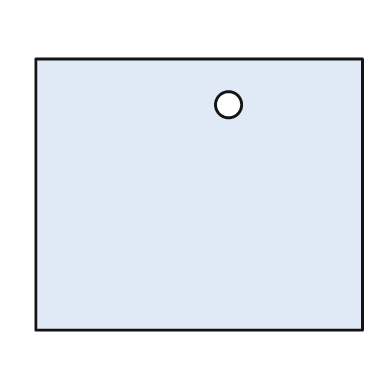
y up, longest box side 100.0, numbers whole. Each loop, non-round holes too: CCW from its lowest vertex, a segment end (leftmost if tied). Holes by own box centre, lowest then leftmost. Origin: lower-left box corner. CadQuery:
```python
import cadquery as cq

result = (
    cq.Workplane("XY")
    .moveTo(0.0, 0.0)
    .lineTo(100.0, 0.0)
    .lineTo(100.0, 83.0)
    .lineTo(0.0, 83.0)
    .close()
    .moveTo(59.0, 69.0)
    .circle(4.0)
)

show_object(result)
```